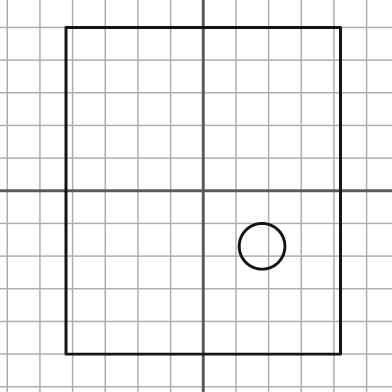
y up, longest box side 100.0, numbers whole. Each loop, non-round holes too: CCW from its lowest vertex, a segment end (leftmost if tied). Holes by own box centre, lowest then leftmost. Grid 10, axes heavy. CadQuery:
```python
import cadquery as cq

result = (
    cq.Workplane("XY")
    .moveTo(-42.0, -50.0)
    .lineTo(42.0, -50.0)
    .lineTo(42.0, 50.0)
    .lineTo(-42.0, 50.0)
    .close()
    .moveTo(18.0, -17.0)
    .circle(7.0)
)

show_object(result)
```